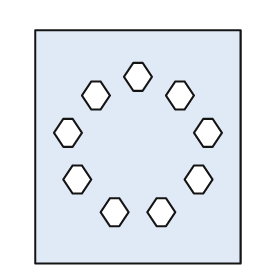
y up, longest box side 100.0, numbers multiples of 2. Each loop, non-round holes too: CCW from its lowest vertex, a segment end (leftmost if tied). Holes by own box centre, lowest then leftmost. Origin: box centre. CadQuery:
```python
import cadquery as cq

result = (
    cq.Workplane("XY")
    .moveTo(-44.0, -50.0)
    .lineTo(44.0, -50.0)
    .lineTo(44.0, 50.0)
    .lineTo(-44.0, 50.0)
    .close()
    .moveTo(-12.0, -34.0)
    .lineTo(-8.0, -34.0)
    .lineTo(-4.0, -28.0)
    .lineTo(-8.0, -22.0)
    .lineTo(-12.0, -22.0)
    .lineTo(-16.0, -28.0)
    .close()
    .moveTo(8.0, -34.0)
    .lineTo(12.0, -34.0)
    .lineTo(16.0, -28.0)
    .lineTo(12.0, -22.0)
    .lineTo(8.0, -22.0)
    .lineTo(4.0, -28.0)
    .close()
    .moveTo(-28.0, -20.0)
    .lineTo(-24.0, -20.0)
    .lineTo(-20.0, -14.0)
    .lineTo(-24.0, -8.0)
    .lineTo(-28.0, -8.0)
    .lineTo(-32.0, -14.0)
    .close()
    .moveTo(24.0, -20.0)
    .lineTo(28.0, -20.0)
    .lineTo(32.0, -14.0)
    .lineTo(28.0, -8.0)
    .lineTo(24.0, -8.0)
    .lineTo(20.0, -14.0)
    .close()
    .moveTo(-32.0, 0.0)
    .lineTo(-28.0, 0.0)
    .lineTo(-24.0, 6.0)
    .lineTo(-28.0, 12.0)
    .lineTo(-32.0, 12.0)
    .lineTo(-36.0, 6.0)
    .close()
    .moveTo(28.0, 0.0)
    .lineTo(32.0, 0.0)
    .lineTo(36.0, 6.0)
    .lineTo(32.0, 12.0)
    .lineTo(28.0, 12.0)
    .lineTo(24.0, 6.0)
    .close()
    .moveTo(-20.0, 16.0)
    .lineTo(-16.0, 16.0)
    .lineTo(-12.0, 22.0)
    .lineTo(-16.0, 28.0)
    .lineTo(-20.0, 28.0)
    .lineTo(-24.0, 22.0)
    .close()
    .moveTo(16.0, 16.0)
    .lineTo(20.0, 16.0)
    .lineTo(24.0, 22.0)
    .lineTo(20.0, 28.0)
    .lineTo(16.0, 28.0)
    .lineTo(12.0, 22.0)
    .close()
    .moveTo(-2.0, 24.0)
    .lineTo(2.0, 24.0)
    .lineTo(6.0, 30.0)
    .lineTo(2.0, 36.0)
    .lineTo(-2.0, 36.0)
    .lineTo(-6.0, 30.0)
    .close()
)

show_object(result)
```